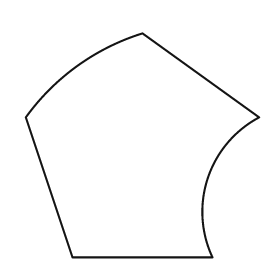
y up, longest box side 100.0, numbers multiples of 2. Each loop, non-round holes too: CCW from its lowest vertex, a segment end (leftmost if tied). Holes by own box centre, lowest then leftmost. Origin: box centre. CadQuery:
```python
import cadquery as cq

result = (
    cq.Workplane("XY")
    .moveTo(-30.0, -48.0)
    .lineTo(30.0, -48.0)
    .threePointArc((28.0, -14.0), (50.0, 12.0))
    .lineTo(0.0, 48.0)
    .threePointArc((-28.0, 34.0), (-50.0, 12.0))
    .close()
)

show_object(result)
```